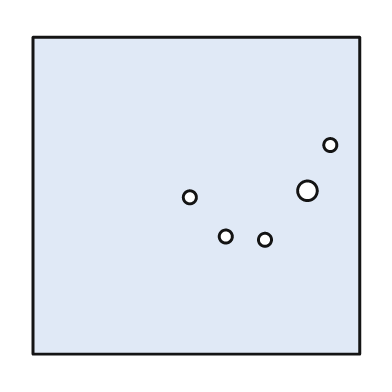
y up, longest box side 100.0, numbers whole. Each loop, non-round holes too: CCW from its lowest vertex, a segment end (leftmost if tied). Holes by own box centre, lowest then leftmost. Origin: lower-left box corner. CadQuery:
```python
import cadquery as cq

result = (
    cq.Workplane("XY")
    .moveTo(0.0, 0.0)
    .lineTo(100.0, 0.0)
    .lineTo(100.0, 97.0)
    .lineTo(0.0, 97.0)
    .close()
    .moveTo(71.0, 35.0)
    .circle(2.0)
    .moveTo(59.0, 36.0)
    .circle(2.0)
    .moveTo(48.0, 48.0)
    .circle(2.0)
    .moveTo(84.0, 50.0)
    .circle(3.0)
    .moveTo(91.0, 64.0)
    .circle(2.0)
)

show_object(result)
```